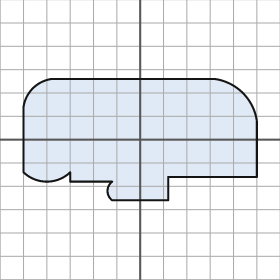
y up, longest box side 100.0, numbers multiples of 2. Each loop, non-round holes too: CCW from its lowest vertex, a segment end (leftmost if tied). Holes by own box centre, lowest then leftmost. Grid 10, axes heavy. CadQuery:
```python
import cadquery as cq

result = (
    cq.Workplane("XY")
    .moveTo(-12.0, -26.0)
    .lineTo(12.0, -26.0)
    .lineTo(12.0, -16.0)
    .lineTo(50.0, -16.0)
    .lineTo(50.0, 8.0)
    .threePointArc((44.0, 20.0), (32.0, 26.0))
    .lineTo(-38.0, 26.0)
    .threePointArc((-46.0, 22.0), (-50.0, 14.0))
    .lineTo(-50.0, -14.0)
    .threePointArc((-40.0, -18.0), (-30.0, -14.0))
    .lineTo(-30.0, -18.0)
    .lineTo(-12.0, -18.0)
    .threePointArc((-14.0, -22.0), (-12.0, -26.0))
    .close()
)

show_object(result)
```